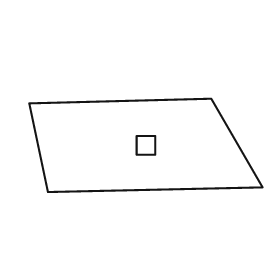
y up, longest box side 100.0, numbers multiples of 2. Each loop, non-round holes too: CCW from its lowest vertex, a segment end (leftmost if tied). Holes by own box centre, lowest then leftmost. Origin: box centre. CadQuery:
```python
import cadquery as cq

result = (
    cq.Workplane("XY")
    .moveTo(-42.0, -20.0)
    .lineTo(50.0, -18.0)
    .lineTo(28.0, 20.0)
    .lineTo(-50.0, 18.0)
    .close()
    .moveTo(-4.0, -4.0)
    .lineTo(4.0, -4.0)
    .lineTo(4.0, 4.0)
    .lineTo(-4.0, 4.0)
    .close()
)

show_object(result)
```